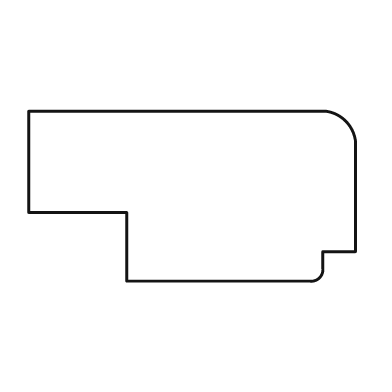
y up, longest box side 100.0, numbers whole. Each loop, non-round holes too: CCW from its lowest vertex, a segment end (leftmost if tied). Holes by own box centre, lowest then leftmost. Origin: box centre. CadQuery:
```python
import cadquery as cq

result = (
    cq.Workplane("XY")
    .moveTo(-20.0, -26.0)
    .lineTo(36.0, -26.0)
    .threePointArc((39.0, -25.0), (40.0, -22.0))
    .lineTo(40.0, -17.0)
    .lineTo(50.0, -17.0)
    .lineTo(50.0, 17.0)
    .threePointArc((47.0, 23.0), (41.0, 26.0))
    .lineTo(-50.0, 26.0)
    .lineTo(-50.0, -5.0)
    .lineTo(-20.0, -5.0)
    .close()
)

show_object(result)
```